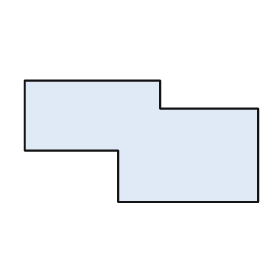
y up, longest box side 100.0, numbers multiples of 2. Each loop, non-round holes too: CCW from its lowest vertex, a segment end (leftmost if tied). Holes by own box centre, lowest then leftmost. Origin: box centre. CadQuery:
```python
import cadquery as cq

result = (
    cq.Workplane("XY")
    .moveTo(-10.0, -26.0)
    .lineTo(50.0, -26.0)
    .lineTo(50.0, 14.0)
    .lineTo(8.0, 14.0)
    .lineTo(8.0, 26.0)
    .lineTo(-50.0, 26.0)
    .lineTo(-50.0, -4.0)
    .lineTo(-10.0, -4.0)
    .close()
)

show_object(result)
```